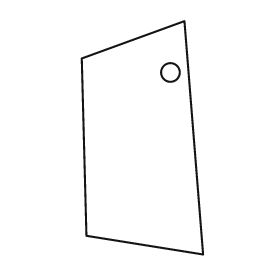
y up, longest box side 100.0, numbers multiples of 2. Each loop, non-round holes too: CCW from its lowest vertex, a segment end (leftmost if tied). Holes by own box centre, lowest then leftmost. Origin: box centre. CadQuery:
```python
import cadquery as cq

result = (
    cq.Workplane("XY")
    .moveTo(26.0, -50.0)
    .lineTo(18.0, 50.0)
    .lineTo(-26.0, 34.0)
    .lineTo(-24.0, -42.0)
    .close()
    .moveTo(12.0, 28.0)
    .circle(4.0)
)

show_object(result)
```